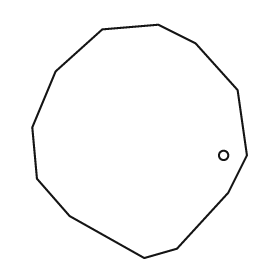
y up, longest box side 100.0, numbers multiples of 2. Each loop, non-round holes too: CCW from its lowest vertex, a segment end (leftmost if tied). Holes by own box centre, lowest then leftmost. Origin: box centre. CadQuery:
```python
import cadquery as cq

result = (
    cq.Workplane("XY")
    .moveTo(2.0, -50.0)
    .lineTo(16.0, -46.0)
    .lineTo(38.0, -22.0)
    .lineTo(46.0, -6.0)
    .lineTo(42.0, 22.0)
    .lineTo(24.0, 42.0)
    .lineTo(8.0, 50.0)
    .lineTo(-16.0, 48.0)
    .lineTo(-36.0, 30.0)
    .lineTo(-46.0, 6.0)
    .lineTo(-44.0, -16.0)
    .lineTo(-30.0, -32.0)
    .close()
    .moveTo(36.0, -6.0)
    .circle(2.0)
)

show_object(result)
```